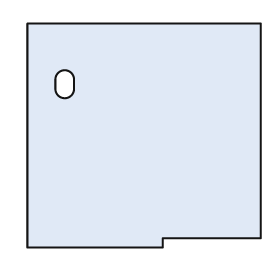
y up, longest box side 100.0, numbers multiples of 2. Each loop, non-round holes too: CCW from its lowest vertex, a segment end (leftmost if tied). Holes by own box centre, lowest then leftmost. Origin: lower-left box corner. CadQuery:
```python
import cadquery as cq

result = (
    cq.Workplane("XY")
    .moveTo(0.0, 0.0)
    .lineTo(58.0, 0.0)
    .lineTo(58.0, 4.0)
    .lineTo(100.0, 4.0)
    .lineTo(100.0, 96.0)
    .lineTo(0.0, 96.0)
    .close()
    .moveTo(12.0, 68.0)
    .threePointArc((16.0, 64.0), (20.0, 68.0))
    .lineTo(20.0, 72.0)
    .threePointArc((16.0, 76.0), (12.0, 72.0))
    .close()
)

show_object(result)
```